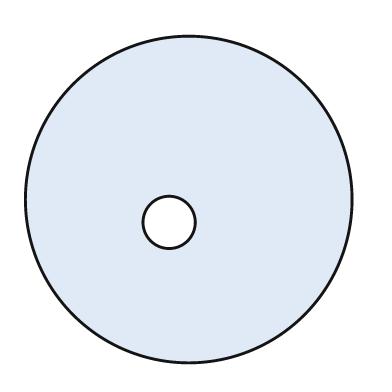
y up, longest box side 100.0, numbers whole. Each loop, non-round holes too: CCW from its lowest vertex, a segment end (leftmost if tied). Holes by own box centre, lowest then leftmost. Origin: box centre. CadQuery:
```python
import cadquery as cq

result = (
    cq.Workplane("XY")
    .moveTo(0.0, 0.0)
    .circle(50.0)
    .moveTo(-6.0, -7.0)
    .circle(8.0)
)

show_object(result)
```